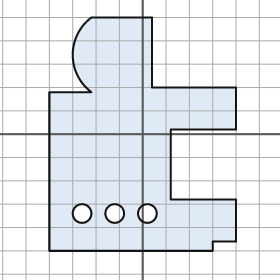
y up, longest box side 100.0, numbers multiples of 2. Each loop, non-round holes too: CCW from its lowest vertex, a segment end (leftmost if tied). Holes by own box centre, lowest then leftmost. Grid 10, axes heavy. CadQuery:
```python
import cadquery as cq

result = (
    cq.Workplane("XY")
    .moveTo(-40.0, -50.0)
    .lineTo(30.0, -50.0)
    .lineTo(30.0, -46.0)
    .lineTo(40.0, -46.0)
    .lineTo(40.0, -28.0)
    .lineTo(12.0, -28.0)
    .lineTo(12.0, 2.0)
    .lineTo(40.0, 2.0)
    .lineTo(40.0, 20.0)
    .lineTo(4.0, 20.0)
    .lineTo(4.0, 50.0)
    .lineTo(-22.0, 50.0)
    .threePointArc((-30.0, 34.0), (-22.0, 18.0))
    .lineTo(-40.0, 18.0)
    .close()
    .moveTo(-26.0, -34.0)
    .circle(4.0)
    .moveTo(-12.0, -34.0)
    .circle(4.0)
    .moveTo(2.0, -34.0)
    .circle(4.0)
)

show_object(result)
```